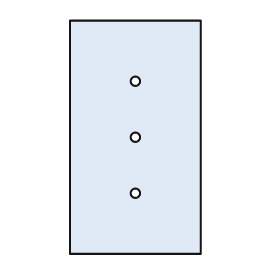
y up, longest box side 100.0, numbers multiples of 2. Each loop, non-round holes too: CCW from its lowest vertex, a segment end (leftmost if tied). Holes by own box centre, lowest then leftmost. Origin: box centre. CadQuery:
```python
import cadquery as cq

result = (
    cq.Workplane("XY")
    .moveTo(-28.0, -50.0)
    .lineTo(28.0, -50.0)
    .lineTo(28.0, 50.0)
    .lineTo(-28.0, 50.0)
    .close()
    .moveTo(0.0, -24.0)
    .circle(2.0)
    .moveTo(0.0, 0.0)
    .circle(2.0)
    .moveTo(0.0, 24.0)
    .circle(2.0)
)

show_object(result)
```